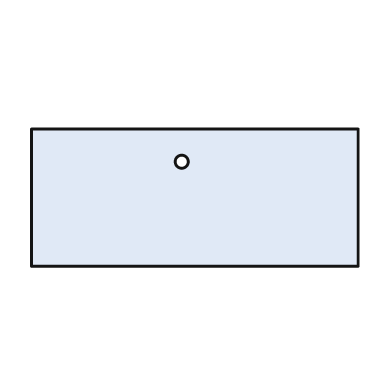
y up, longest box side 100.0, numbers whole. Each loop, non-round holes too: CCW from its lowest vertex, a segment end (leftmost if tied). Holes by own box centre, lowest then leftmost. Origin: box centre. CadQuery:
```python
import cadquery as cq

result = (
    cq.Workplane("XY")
    .moveTo(-50.0, -21.0)
    .lineTo(50.0, -21.0)
    .lineTo(50.0, 21.0)
    .lineTo(-50.0, 21.0)
    .close()
    .moveTo(-4.0, 11.0)
    .circle(2.0)
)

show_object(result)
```